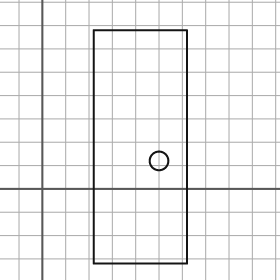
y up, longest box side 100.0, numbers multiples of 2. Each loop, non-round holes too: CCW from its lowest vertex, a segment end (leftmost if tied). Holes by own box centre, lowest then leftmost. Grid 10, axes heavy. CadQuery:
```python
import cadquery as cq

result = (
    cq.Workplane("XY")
    .moveTo(22.0, -32.0)
    .lineTo(62.0, -32.0)
    .lineTo(62.0, 68.0)
    .lineTo(22.0, 68.0)
    .close()
    .moveTo(50.0, 12.0)
    .circle(4.0)
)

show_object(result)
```